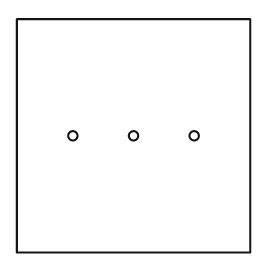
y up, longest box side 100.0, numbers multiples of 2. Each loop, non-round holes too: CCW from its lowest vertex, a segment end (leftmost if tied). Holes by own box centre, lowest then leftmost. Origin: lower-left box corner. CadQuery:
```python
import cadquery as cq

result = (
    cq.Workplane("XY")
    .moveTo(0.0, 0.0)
    .lineTo(100.0, 0.0)
    .lineTo(100.0, 100.0)
    .lineTo(0.0, 100.0)
    .close()
    .moveTo(24.0, 50.0)
    .circle(2.0)
    .moveTo(50.0, 50.0)
    .circle(2.0)
    .moveTo(76.0, 50.0)
    .circle(2.0)
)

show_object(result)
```